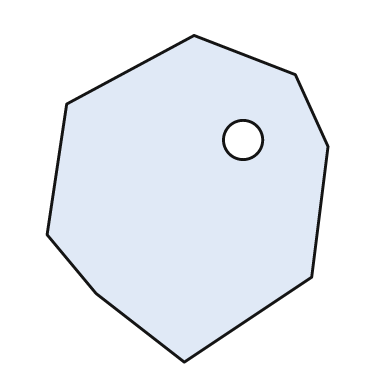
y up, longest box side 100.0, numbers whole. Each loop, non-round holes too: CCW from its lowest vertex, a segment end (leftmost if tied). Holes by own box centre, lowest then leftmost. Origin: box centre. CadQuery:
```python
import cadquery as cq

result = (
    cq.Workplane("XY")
    .moveTo(-1.0, -50.0)
    .lineTo(38.0, -24.0)
    .lineTo(43.0, 16.0)
    .lineTo(33.0, 38.0)
    .lineTo(2.0, 50.0)
    .lineTo(-37.0, 29.0)
    .lineTo(-43.0, -11.0)
    .lineTo(-28.0, -29.0)
    .close()
    .moveTo(17.0, 18.0)
    .circle(6.0)
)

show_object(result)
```